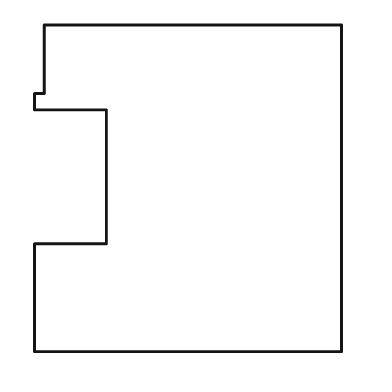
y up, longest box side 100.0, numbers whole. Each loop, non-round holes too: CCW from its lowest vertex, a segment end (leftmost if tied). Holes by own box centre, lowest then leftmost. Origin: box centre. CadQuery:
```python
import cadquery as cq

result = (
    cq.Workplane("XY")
    .moveTo(-47.0, -50.0)
    .lineTo(47.0, -50.0)
    .lineTo(47.0, 50.0)
    .lineTo(-44.0, 50.0)
    .lineTo(-44.0, 29.0)
    .lineTo(-47.0, 29.0)
    .lineTo(-47.0, 24.0)
    .lineTo(-25.0, 24.0)
    .lineTo(-25.0, -17.0)
    .lineTo(-47.0, -17.0)
    .close()
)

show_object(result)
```